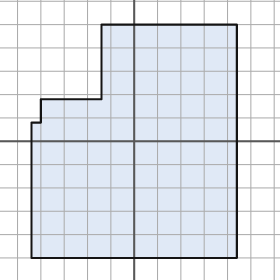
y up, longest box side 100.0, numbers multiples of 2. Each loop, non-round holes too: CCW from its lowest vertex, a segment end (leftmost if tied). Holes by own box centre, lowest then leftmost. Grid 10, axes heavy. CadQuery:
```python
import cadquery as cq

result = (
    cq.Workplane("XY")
    .moveTo(-44.0, -50.0)
    .lineTo(44.0, -50.0)
    .lineTo(44.0, 50.0)
    .lineTo(-14.0, 50.0)
    .lineTo(-14.0, 18.0)
    .lineTo(-40.0, 18.0)
    .lineTo(-40.0, 8.0)
    .lineTo(-44.0, 8.0)
    .close()
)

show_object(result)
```